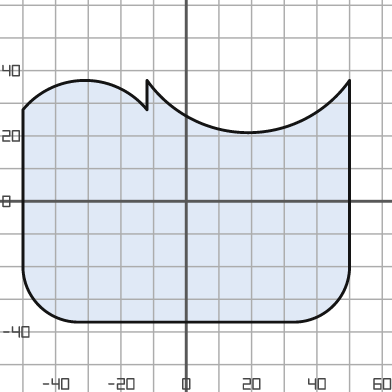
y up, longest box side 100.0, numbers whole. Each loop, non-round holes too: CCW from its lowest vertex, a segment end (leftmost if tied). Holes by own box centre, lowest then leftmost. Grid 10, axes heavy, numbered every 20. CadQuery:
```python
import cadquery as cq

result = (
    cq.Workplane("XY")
    .moveTo(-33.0, -37.0)
    .lineTo(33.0, -37.0)
    .threePointArc((45.0, -32.0), (50.0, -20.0))
    .lineTo(50.0, 37.0)
    .threePointArc((19.0, 21.0), (-12.0, 37.0))
    .lineTo(-12.0, 28.0)
    .threePointArc((-31.0, 37.0), (-50.0, 28.0))
    .lineTo(-50.0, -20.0)
    .threePointArc((-45.0, -32.0), (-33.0, -37.0))
    .close()
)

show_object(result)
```